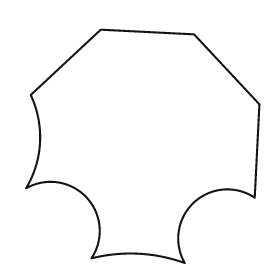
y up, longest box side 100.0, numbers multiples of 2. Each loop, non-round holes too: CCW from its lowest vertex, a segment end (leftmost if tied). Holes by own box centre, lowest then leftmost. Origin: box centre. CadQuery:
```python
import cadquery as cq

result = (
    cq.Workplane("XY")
    .moveTo(18.0, -50.0)
    .threePointArc((22.0, -24.0), (48.0, -22.0))
    .lineTo(50.0, 18.0)
    .lineTo(22.0, 48.0)
    .lineTo(-18.0, 50.0)
    .lineTo(-48.0, 22.0)
    .threePointArc((-44.0, 2.0), (-50.0, -18.0))
    .threePointArc((-24.0, -22.0), (-22.0, -48.0))
    .threePointArc((-2.0, -46.0), (18.0, -50.0))
    .close()
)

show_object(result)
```